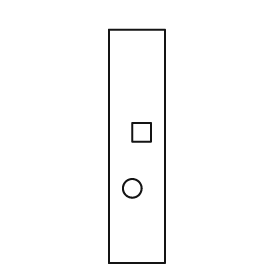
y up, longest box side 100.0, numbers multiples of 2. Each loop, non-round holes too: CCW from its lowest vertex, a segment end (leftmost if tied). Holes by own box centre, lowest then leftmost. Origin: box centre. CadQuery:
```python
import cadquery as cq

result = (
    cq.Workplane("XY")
    .moveTo(-12.0, -50.0)
    .lineTo(12.0, -50.0)
    .lineTo(12.0, 50.0)
    .lineTo(-12.0, 50.0)
    .close()
    .moveTo(-2.0, -18.0)
    .circle(4.0)
    .moveTo(-2.0, 2.0)
    .lineTo(6.0, 2.0)
    .lineTo(6.0, 10.0)
    .lineTo(-2.0, 10.0)
    .close()
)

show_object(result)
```